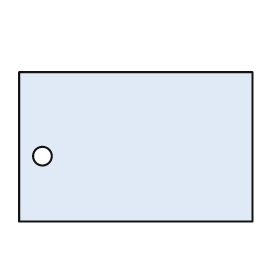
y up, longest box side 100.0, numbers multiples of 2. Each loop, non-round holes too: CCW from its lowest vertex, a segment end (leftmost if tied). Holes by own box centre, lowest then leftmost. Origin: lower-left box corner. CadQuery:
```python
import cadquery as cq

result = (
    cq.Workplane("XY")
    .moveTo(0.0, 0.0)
    .lineTo(100.0, 0.0)
    .lineTo(100.0, 64.0)
    .lineTo(0.0, 64.0)
    .close()
    .moveTo(10.0, 28.0)
    .circle(4.0)
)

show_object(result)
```